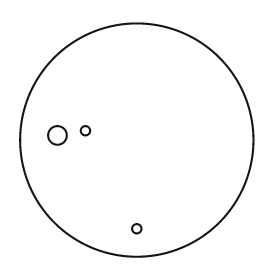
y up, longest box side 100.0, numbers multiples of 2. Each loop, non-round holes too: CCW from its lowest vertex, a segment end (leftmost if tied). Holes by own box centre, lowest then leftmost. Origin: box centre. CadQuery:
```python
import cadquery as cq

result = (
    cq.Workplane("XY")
    .moveTo(0.0, 0.0)
    .circle(50.0)
    .moveTo(0.0, -38.0)
    .circle(2.0)
    .moveTo(-34.0, 2.0)
    .circle(4.0)
    .moveTo(-22.0, 4.0)
    .circle(2.0)
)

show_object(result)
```